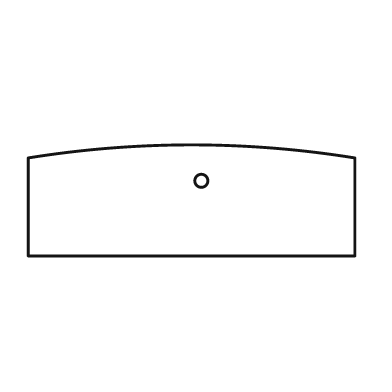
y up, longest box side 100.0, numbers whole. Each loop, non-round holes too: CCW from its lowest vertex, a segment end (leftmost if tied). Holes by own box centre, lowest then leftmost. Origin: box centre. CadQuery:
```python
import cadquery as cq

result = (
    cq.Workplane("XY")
    .moveTo(-50.0, -17.0)
    .lineTo(50.0, -17.0)
    .lineTo(50.0, 13.0)
    .threePointArc((0.0, 17.0), (-50.0, 13.0))
    .close()
    .moveTo(3.0, 6.0)
    .circle(2.0)
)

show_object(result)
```